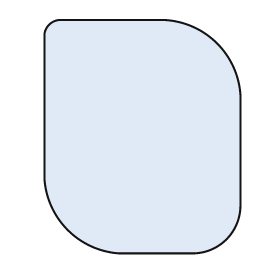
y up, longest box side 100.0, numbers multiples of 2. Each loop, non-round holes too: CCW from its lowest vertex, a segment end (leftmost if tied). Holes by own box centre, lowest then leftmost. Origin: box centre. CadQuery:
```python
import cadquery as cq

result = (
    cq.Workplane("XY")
    .moveTo(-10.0, -50.0)
    .lineTo(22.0, -50.0)
    .threePointArc((36.0, -44.0), (42.0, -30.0))
    .lineTo(42.0, 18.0)
    .threePointArc((32.0, 40.0), (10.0, 50.0))
    .lineTo(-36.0, 50.0)
    .threePointArc((-40.0, 48.0), (-42.0, 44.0))
    .lineTo(-42.0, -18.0)
    .threePointArc((-32.0, -40.0), (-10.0, -50.0))
    .close()
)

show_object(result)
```